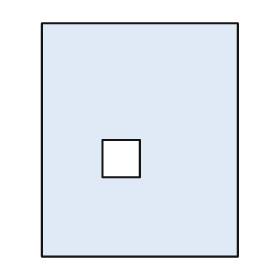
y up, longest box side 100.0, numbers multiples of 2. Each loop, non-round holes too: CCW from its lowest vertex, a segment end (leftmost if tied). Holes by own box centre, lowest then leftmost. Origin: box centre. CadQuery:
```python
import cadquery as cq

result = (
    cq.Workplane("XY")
    .moveTo(-42.0, -50.0)
    .lineTo(42.0, -50.0)
    .lineTo(42.0, 50.0)
    .lineTo(-42.0, 50.0)
    .close()
    .moveTo(-16.0, -16.0)
    .lineTo(0.0, -16.0)
    .lineTo(0.0, 0.0)
    .lineTo(-16.0, 0.0)
    .close()
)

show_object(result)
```